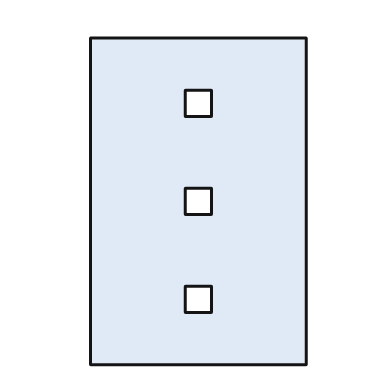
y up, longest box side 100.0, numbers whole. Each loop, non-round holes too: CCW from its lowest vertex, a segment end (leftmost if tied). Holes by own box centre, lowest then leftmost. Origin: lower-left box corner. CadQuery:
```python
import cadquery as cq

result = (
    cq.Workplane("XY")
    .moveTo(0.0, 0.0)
    .lineTo(66.0, 0.0)
    .lineTo(66.0, 100.0)
    .lineTo(0.0, 100.0)
    .close()
    .moveTo(29.0, 16.0)
    .lineTo(37.0, 16.0)
    .lineTo(37.0, 24.0)
    .lineTo(29.0, 24.0)
    .close()
    .moveTo(29.0, 46.0)
    .lineTo(37.0, 46.0)
    .lineTo(37.0, 54.0)
    .lineTo(29.0, 54.0)
    .close()
    .moveTo(29.0, 76.0)
    .lineTo(37.0, 76.0)
    .lineTo(37.0, 84.0)
    .lineTo(29.0, 84.0)
    .close()
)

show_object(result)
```